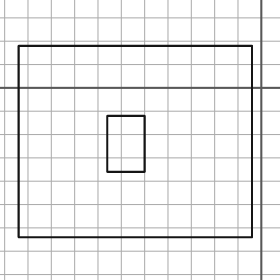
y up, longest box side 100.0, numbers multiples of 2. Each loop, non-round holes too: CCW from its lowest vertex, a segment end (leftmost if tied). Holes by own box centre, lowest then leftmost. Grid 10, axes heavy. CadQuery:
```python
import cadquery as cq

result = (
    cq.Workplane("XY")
    .moveTo(-104.0, -64.0)
    .lineTo(-4.0, -64.0)
    .lineTo(-4.0, 18.0)
    .lineTo(-104.0, 18.0)
    .close()
    .moveTo(-66.0, -36.0)
    .lineTo(-50.0, -36.0)
    .lineTo(-50.0, -12.0)
    .lineTo(-66.0, -12.0)
    .close()
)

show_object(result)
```